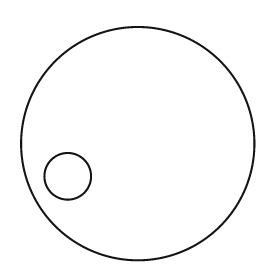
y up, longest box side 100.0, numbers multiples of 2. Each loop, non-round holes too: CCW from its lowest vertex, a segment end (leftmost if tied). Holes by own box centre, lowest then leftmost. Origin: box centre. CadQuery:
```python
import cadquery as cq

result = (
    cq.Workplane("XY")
    .moveTo(0.0, 0.0)
    .circle(50.0)
    .moveTo(-30.0, -14.0)
    .circle(10.0)
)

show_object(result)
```